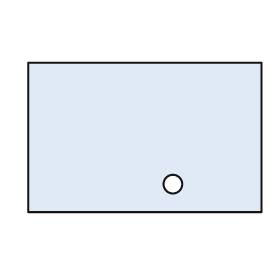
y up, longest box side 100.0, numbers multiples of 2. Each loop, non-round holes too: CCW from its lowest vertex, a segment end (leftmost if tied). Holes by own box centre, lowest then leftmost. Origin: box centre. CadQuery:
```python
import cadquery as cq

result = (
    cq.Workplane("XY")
    .moveTo(-50.0, -32.0)
    .lineTo(50.0, -32.0)
    .lineTo(50.0, 32.0)
    .lineTo(-50.0, 32.0)
    .close()
    .moveTo(12.0, -20.0)
    .circle(4.0)
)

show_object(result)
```